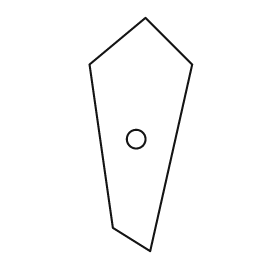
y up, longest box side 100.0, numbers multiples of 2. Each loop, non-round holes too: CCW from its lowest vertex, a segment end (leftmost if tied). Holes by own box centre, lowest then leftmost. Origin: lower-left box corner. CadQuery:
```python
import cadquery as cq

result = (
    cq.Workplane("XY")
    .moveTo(26.0, 0.0)
    .lineTo(44.0, 80.0)
    .lineTo(24.0, 100.0)
    .lineTo(0.0, 80.0)
    .lineTo(10.0, 10.0)
    .close()
    .moveTo(20.0, 48.0)
    .circle(4.0)
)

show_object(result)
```